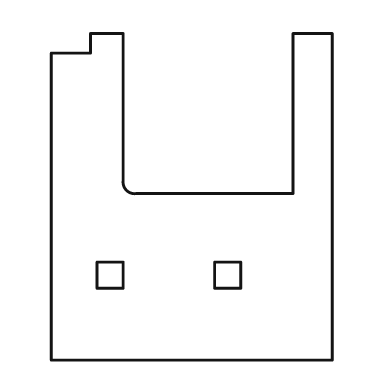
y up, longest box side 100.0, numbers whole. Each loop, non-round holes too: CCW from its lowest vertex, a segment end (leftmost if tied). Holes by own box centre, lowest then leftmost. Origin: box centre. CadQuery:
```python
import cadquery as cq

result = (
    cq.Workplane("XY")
    .moveTo(-43.0, -50.0)
    .lineTo(43.0, -50.0)
    .lineTo(43.0, 50.0)
    .lineTo(31.0, 50.0)
    .lineTo(31.0, 1.0)
    .lineTo(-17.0, 1.0)
    .threePointArc((-20.0, 2.0), (-21.0, 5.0))
    .lineTo(-21.0, 50.0)
    .lineTo(-31.0, 50.0)
    .lineTo(-31.0, 44.0)
    .lineTo(-43.0, 44.0)
    .close()
    .moveTo(-29.0, -28.0)
    .lineTo(-21.0, -28.0)
    .lineTo(-21.0, -20.0)
    .lineTo(-29.0, -20.0)
    .close()
    .moveTo(7.0, -28.0)
    .lineTo(15.0, -28.0)
    .lineTo(15.0, -20.0)
    .lineTo(7.0, -20.0)
    .close()
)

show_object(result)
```